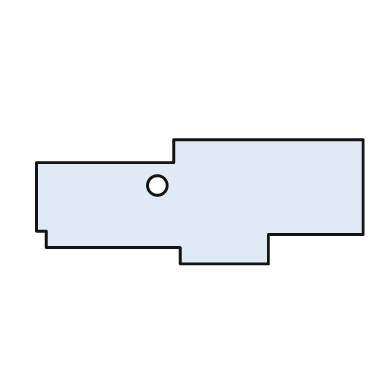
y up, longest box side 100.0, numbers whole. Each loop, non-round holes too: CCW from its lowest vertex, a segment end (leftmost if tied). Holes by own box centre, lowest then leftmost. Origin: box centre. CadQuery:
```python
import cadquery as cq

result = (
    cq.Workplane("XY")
    .moveTo(-6.0, -19.0)
    .lineTo(21.0, -19.0)
    .lineTo(21.0, -10.0)
    .lineTo(50.0, -10.0)
    .lineTo(50.0, 19.0)
    .lineTo(-8.0, 19.0)
    .lineTo(-8.0, 12.0)
    .lineTo(-50.0, 12.0)
    .lineTo(-50.0, -9.0)
    .lineTo(-47.0, -9.0)
    .lineTo(-47.0, -14.0)
    .lineTo(-6.0, -14.0)
    .close()
    .moveTo(-13.0, 5.0)
    .circle(3.0)
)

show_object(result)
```